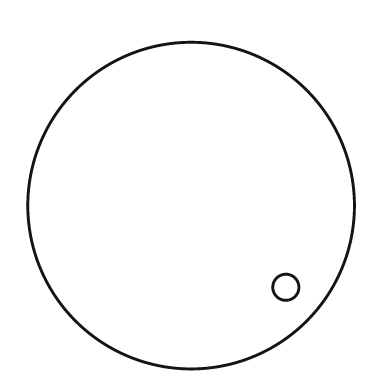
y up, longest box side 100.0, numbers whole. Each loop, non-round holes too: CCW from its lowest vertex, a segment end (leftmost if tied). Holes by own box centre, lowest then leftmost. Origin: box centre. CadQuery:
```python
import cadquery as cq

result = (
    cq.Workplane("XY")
    .moveTo(0.0, 0.0)
    .circle(50.0)
    .moveTo(29.0, -25.0)
    .circle(4.0)
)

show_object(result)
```